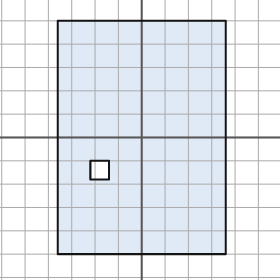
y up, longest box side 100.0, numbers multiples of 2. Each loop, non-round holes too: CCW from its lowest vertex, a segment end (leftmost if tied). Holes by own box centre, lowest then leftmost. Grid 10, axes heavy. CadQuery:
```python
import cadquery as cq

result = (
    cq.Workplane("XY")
    .moveTo(-36.0, -50.0)
    .lineTo(36.0, -50.0)
    .lineTo(36.0, 50.0)
    .lineTo(-36.0, 50.0)
    .close()
    .moveTo(-22.0, -18.0)
    .lineTo(-14.0, -18.0)
    .lineTo(-14.0, -10.0)
    .lineTo(-22.0, -10.0)
    .close()
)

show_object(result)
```